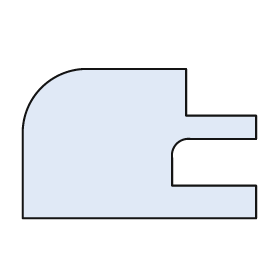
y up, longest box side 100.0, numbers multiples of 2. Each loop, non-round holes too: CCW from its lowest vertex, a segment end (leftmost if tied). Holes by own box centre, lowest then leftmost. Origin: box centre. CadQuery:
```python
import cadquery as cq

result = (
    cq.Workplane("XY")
    .moveTo(-50.0, -32.0)
    .lineTo(50.0, -32.0)
    .lineTo(50.0, -18.0)
    .lineTo(14.0, -18.0)
    .lineTo(14.0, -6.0)
    .threePointArc((16.0, 0.0), (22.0, 2.0))
    .lineTo(50.0, 2.0)
    .lineTo(50.0, 12.0)
    .lineTo(20.0, 12.0)
    .lineTo(20.0, 32.0)
    .lineTo(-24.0, 32.0)
    .threePointArc((-42.0, 24.0), (-50.0, 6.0))
    .close()
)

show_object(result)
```